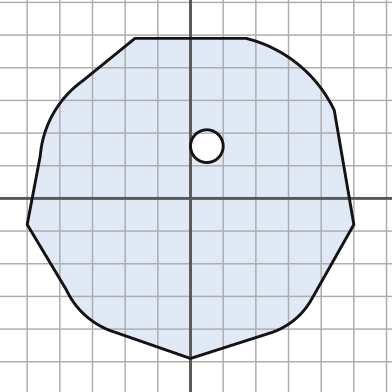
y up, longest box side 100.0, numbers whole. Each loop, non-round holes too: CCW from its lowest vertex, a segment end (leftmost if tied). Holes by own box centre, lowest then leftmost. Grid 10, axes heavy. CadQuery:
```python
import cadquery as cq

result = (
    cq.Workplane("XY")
    .moveTo(0.0, -49.0)
    .lineTo(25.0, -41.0)
    .threePointArc((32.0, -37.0), (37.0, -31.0))
    .lineTo(50.0, -8.0)
    .lineTo(44.0, 27.0)
    .threePointArc((33.0, 41.0), (17.0, 49.0))
    .lineTo(-17.0, 49.0)
    .lineTo(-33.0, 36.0)
    .threePointArc((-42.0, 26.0), (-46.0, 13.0))
    .lineTo(-50.0, -8.0)
    .lineTo(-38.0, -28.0)
    .threePointArc((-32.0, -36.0), (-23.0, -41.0))
    .close()
    .moveTo(5.0, 16.0)
    .circle(5.0)
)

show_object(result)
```